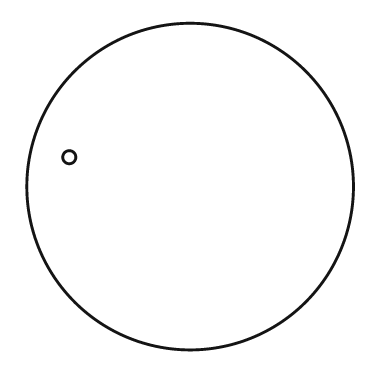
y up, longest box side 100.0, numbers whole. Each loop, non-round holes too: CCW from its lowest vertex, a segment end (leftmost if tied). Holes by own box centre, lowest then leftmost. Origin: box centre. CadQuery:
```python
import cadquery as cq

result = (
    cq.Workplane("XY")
    .moveTo(0.0, 0.0)
    .circle(50.0)
    .moveTo(-37.0, 9.0)
    .circle(2.0)
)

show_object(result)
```